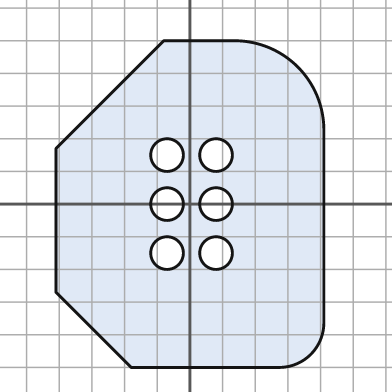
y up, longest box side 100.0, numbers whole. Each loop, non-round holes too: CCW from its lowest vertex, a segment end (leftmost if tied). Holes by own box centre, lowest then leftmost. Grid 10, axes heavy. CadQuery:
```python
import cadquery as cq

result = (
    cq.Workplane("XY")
    .moveTo(-18.0, -50.0)
    .lineTo(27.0, -50.0)
    .threePointArc((37.0, -46.0), (41.0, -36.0))
    .lineTo(41.0, 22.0)
    .threePointArc((33.0, 42.0), (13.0, 50.0))
    .lineTo(-8.0, 50.0)
    .lineTo(-41.0, 17.0)
    .lineTo(-41.0, -27.0)
    .close()
    .moveTo(-7.0, -15.0)
    .circle(5.0)
    .moveTo(8.0, -15.0)
    .circle(5.0)
    .moveTo(-7.0, 0.0)
    .circle(5.0)
    .moveTo(8.0, 0.0)
    .circle(5.0)
    .moveTo(-7.0, 15.0)
    .circle(5.0)
    .moveTo(8.0, 15.0)
    .circle(5.0)
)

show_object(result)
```